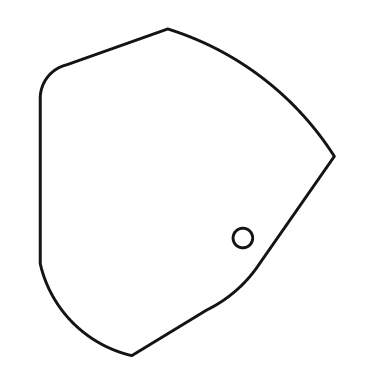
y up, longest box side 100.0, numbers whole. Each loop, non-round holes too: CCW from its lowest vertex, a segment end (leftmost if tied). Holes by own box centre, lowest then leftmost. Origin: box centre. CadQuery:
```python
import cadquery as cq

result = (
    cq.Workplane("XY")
    .moveTo(-17.0, -50.0)
    .lineTo(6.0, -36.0)
    .threePointArc((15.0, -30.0), (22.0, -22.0))
    .lineTo(45.0, 11.0)
    .threePointArc((23.0, 35.0), (-6.0, 50.0))
    .lineTo(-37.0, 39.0)
    .threePointArc((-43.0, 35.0), (-45.0, 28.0))
    .lineTo(-45.0, -22.0)
    .threePointArc((-35.0, -40.0), (-17.0, -50.0))
    .close()
    .moveTo(17.0, -14.0)
    .circle(3.0)
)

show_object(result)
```